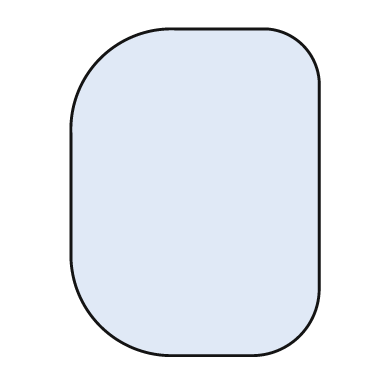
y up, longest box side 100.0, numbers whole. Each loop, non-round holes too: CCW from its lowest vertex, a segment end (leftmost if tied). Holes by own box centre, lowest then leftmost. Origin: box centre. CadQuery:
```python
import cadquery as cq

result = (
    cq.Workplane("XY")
    .moveTo(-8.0, -50.0)
    .lineTo(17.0, -50.0)
    .threePointArc((32.0, -44.0), (38.0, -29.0))
    .lineTo(38.0, 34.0)
    .threePointArc((33.0, 45.0), (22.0, 50.0))
    .lineTo(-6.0, 50.0)
    .threePointArc((-29.0, 41.0), (-38.0, 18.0))
    .lineTo(-38.0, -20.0)
    .threePointArc((-29.0, -41.0), (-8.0, -50.0))
    .close()
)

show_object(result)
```